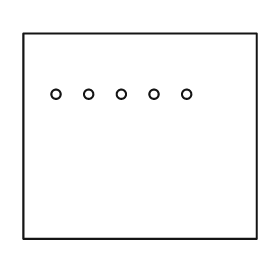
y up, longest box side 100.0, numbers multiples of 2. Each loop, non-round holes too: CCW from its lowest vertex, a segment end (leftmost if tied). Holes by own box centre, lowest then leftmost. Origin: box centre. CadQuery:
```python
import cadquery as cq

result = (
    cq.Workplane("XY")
    .moveTo(-50.0, -44.0)
    .lineTo(50.0, -44.0)
    .lineTo(50.0, 44.0)
    .lineTo(-50.0, 44.0)
    .close()
    .moveTo(-36.0, 18.0)
    .circle(2.0)
    .moveTo(-22.0, 18.0)
    .circle(2.0)
    .moveTo(-8.0, 18.0)
    .circle(2.0)
    .moveTo(6.0, 18.0)
    .circle(2.0)
    .moveTo(20.0, 18.0)
    .circle(2.0)
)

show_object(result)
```